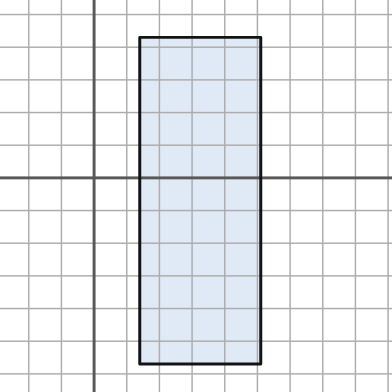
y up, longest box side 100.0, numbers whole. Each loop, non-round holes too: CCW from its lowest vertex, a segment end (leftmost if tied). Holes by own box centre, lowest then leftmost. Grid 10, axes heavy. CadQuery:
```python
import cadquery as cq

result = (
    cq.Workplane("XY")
    .moveTo(14.0, -57.0)
    .lineTo(51.0, -57.0)
    .lineTo(51.0, 43.0)
    .lineTo(14.0, 43.0)
    .close()
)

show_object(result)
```